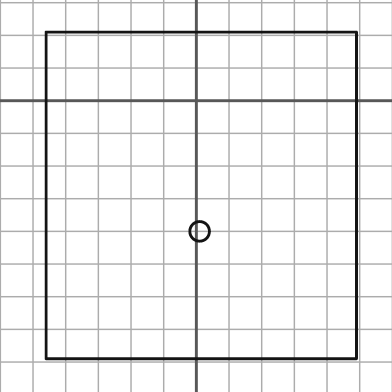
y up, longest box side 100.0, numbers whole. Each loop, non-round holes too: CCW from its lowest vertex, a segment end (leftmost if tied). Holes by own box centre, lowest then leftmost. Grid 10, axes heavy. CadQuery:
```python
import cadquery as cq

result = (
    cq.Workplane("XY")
    .moveTo(-46.0, -79.0)
    .lineTo(49.0, -79.0)
    .lineTo(49.0, 21.0)
    .lineTo(-46.0, 21.0)
    .close()
    .moveTo(1.0, -40.0)
    .circle(3.0)
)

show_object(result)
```